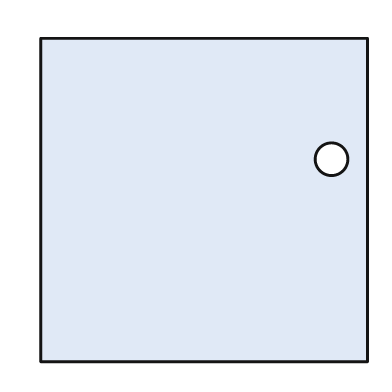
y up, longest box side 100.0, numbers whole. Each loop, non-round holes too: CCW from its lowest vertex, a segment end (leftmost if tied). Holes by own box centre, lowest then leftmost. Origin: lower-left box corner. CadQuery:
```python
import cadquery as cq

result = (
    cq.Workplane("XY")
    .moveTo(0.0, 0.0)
    .lineTo(100.0, 0.0)
    .lineTo(100.0, 99.0)
    .lineTo(0.0, 99.0)
    .close()
    .moveTo(89.0, 62.0)
    .circle(5.0)
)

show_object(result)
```